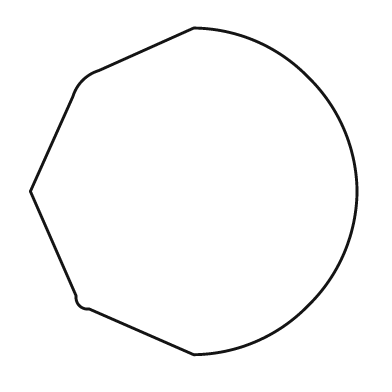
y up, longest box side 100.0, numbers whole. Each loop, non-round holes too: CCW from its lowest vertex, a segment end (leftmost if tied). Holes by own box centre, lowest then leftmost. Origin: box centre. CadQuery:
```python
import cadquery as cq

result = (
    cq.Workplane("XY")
    .moveTo(0.0, -50.0)
    .threePointArc((19.0, -46.0), (35.0, -35.0))
    .threePointArc((46.0, -19.0), (50.0, 0.0))
    .threePointArc((46.0, 19.0), (35.0, 35.0))
    .threePointArc((19.0, 46.0), (0.0, 50.0))
    .lineTo(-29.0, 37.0)
    .threePointArc((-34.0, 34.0), (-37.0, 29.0))
    .lineTo(-50.0, 0.0)
    .lineTo(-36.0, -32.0)
    .threePointArc((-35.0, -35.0), (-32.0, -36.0))
    .close()
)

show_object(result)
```